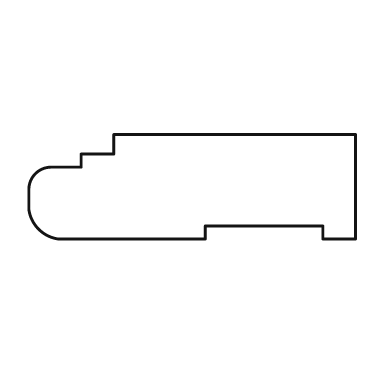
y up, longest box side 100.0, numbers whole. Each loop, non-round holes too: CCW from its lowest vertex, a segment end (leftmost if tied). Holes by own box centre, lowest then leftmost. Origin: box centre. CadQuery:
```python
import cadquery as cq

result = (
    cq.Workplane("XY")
    .moveTo(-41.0, -16.0)
    .lineTo(4.0, -16.0)
    .lineTo(4.0, -12.0)
    .lineTo(40.0, -12.0)
    .lineTo(40.0, -16.0)
    .lineTo(50.0, -16.0)
    .lineTo(50.0, 16.0)
    .lineTo(-24.0, 16.0)
    .lineTo(-24.0, 10.0)
    .lineTo(-34.0, 10.0)
    .lineTo(-34.0, 6.0)
    .lineTo(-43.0, 6.0)
    .threePointArc((-48.0, 4.0), (-50.0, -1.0))
    .lineTo(-50.0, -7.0)
    .threePointArc((-47.0, -13.0), (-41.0, -16.0))
    .close()
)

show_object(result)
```